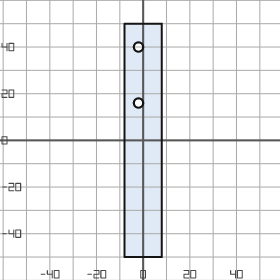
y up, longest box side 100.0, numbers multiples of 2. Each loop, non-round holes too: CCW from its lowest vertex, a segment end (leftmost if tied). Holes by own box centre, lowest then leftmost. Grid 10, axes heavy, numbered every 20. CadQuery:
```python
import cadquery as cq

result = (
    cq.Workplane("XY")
    .moveTo(-8.0, -50.0)
    .lineTo(8.0, -50.0)
    .lineTo(8.0, 50.0)
    .lineTo(-8.0, 50.0)
    .close()
    .moveTo(-2.0, 16.0)
    .circle(2.0)
    .moveTo(-2.0, 40.0)
    .circle(2.0)
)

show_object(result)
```